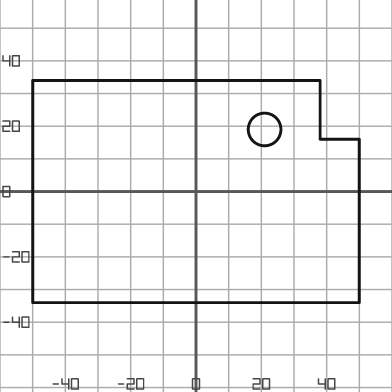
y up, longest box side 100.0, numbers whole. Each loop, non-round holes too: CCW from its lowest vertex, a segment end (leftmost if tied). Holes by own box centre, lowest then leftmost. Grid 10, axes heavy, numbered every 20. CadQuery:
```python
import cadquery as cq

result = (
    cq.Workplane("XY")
    .moveTo(-50.0, -34.0)
    .lineTo(50.0, -34.0)
    .lineTo(50.0, 16.0)
    .lineTo(38.0, 16.0)
    .lineTo(38.0, 34.0)
    .lineTo(-50.0, 34.0)
    .close()
    .moveTo(21.0, 19.0)
    .circle(5.0)
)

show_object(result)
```